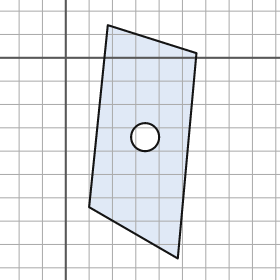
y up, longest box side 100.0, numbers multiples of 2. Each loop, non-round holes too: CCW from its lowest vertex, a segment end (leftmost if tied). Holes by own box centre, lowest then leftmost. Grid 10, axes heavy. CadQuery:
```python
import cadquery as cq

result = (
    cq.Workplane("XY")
    .moveTo(48.0, -86.0)
    .lineTo(56.0, 2.0)
    .lineTo(18.0, 14.0)
    .lineTo(10.0, -64.0)
    .close()
    .moveTo(34.0, -34.0)
    .circle(6.0)
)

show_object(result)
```